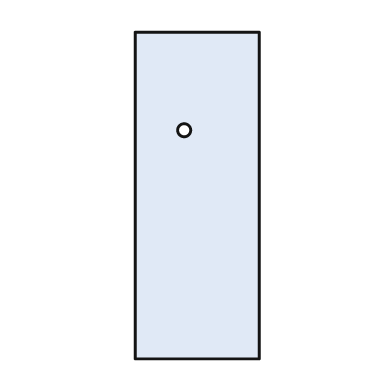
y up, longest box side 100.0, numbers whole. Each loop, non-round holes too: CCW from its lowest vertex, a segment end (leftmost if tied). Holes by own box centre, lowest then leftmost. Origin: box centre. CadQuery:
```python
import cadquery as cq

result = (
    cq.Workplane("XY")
    .moveTo(-19.0, -50.0)
    .lineTo(19.0, -50.0)
    .lineTo(19.0, 50.0)
    .lineTo(-19.0, 50.0)
    .close()
    .moveTo(-4.0, 20.0)
    .circle(2.0)
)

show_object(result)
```